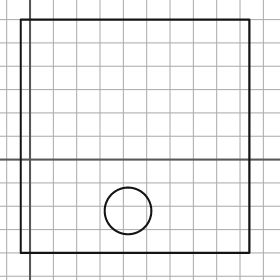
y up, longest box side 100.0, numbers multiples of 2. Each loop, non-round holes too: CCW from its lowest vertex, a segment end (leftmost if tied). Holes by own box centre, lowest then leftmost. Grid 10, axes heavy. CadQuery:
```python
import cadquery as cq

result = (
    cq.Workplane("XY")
    .moveTo(-4.0, -40.0)
    .lineTo(94.0, -40.0)
    .lineTo(94.0, 60.0)
    .lineTo(-4.0, 60.0)
    .close()
    .moveTo(42.0, -22.0)
    .circle(10.0)
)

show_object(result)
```